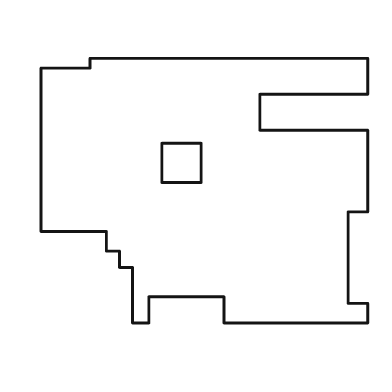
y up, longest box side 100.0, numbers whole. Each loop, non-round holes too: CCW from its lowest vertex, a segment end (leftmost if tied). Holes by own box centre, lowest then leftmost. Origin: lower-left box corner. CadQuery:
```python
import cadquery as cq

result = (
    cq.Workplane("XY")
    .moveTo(28.0, 0.0)
    .lineTo(33.0, 0.0)
    .lineTo(33.0, 8.0)
    .lineTo(56.0, 8.0)
    .lineTo(56.0, 0.0)
    .lineTo(100.0, 0.0)
    .lineTo(100.0, 6.0)
    .lineTo(94.0, 6.0)
    .lineTo(94.0, 34.0)
    .lineTo(100.0, 34.0)
    .lineTo(100.0, 59.0)
    .lineTo(67.0, 59.0)
    .lineTo(67.0, 70.0)
    .lineTo(100.0, 70.0)
    .lineTo(100.0, 81.0)
    .lineTo(15.0, 81.0)
    .lineTo(15.0, 78.0)
    .lineTo(0.0, 78.0)
    .lineTo(0.0, 28.0)
    .lineTo(20.0, 28.0)
    .lineTo(20.0, 22.0)
    .lineTo(24.0, 22.0)
    .lineTo(24.0, 17.0)
    .lineTo(28.0, 17.0)
    .close()
    .moveTo(37.0, 43.0)
    .lineTo(49.0, 43.0)
    .lineTo(49.0, 55.0)
    .lineTo(37.0, 55.0)
    .close()
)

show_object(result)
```